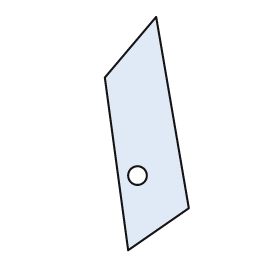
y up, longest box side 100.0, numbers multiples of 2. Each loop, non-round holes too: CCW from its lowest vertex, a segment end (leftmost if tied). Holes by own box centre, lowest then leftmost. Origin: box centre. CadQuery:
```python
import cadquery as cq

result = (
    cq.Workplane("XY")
    .moveTo(-8.0, -50.0)
    .lineTo(18.0, -32.0)
    .lineTo(4.0, 50.0)
    .lineTo(-18.0, 24.0)
    .close()
    .moveTo(-4.0, -18.0)
    .circle(4.0)
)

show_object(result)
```